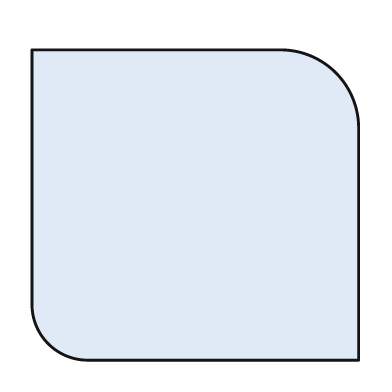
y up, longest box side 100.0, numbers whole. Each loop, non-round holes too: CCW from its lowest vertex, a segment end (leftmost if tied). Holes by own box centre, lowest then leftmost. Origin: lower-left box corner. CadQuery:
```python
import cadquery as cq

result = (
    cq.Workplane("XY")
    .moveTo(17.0, 0.0)
    .lineTo(100.0, 0.0)
    .lineTo(100.0, 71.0)
    .threePointArc((93.0, 88.0), (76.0, 95.0))
    .lineTo(0.0, 95.0)
    .lineTo(0.0, 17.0)
    .threePointArc((5.0, 5.0), (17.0, 0.0))
    .close()
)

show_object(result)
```